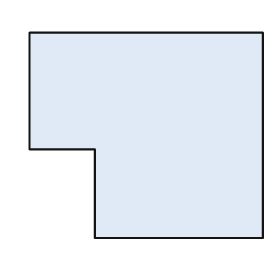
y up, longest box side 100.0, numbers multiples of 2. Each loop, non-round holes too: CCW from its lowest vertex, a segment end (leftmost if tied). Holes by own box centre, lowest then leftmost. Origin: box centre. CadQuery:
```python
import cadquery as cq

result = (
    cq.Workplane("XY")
    .moveTo(-22.0, -44.0)
    .lineTo(50.0, -44.0)
    .lineTo(50.0, 44.0)
    .lineTo(-50.0, 44.0)
    .lineTo(-50.0, -6.0)
    .lineTo(-22.0, -6.0)
    .close()
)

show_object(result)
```